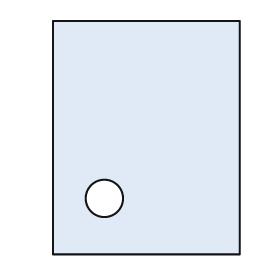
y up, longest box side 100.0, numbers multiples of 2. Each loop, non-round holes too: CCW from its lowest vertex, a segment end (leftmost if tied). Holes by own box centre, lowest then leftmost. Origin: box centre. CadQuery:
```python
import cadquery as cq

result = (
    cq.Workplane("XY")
    .moveTo(-40.0, -50.0)
    .lineTo(40.0, -50.0)
    .lineTo(40.0, 50.0)
    .lineTo(-40.0, 50.0)
    .close()
    .moveTo(-18.0, -26.0)
    .circle(8.0)
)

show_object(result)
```